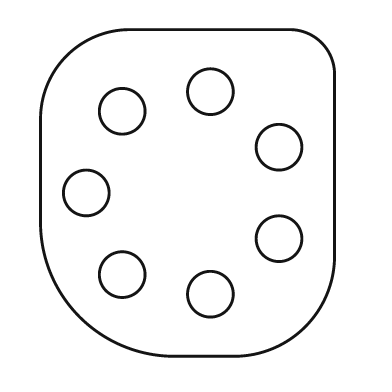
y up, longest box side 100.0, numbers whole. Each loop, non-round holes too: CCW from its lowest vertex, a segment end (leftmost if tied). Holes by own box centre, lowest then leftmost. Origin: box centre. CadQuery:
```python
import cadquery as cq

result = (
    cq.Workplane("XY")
    .moveTo(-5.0, -50.0)
    .lineTo(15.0, -50.0)
    .threePointArc((36.0, -41.0), (45.0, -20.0))
    .lineTo(45.0, 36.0)
    .threePointArc((41.0, 46.0), (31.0, 50.0))
    .lineTo(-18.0, 50.0)
    .threePointArc((-37.0, 42.0), (-45.0, 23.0))
    .lineTo(-45.0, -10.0)
    .threePointArc((-33.0, -38.0), (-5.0, -50.0))
    .close()
    .moveTo(7.0, -31.0)
    .circle(7.0)
    .moveTo(-20.0, -25.0)
    .circle(7.0)
    .moveTo(28.0, -14.0)
    .circle(7.0)
    .moveTo(-31.0, 0.0)
    .circle(7.0)
    .moveTo(28.0, 14.0)
    .circle(7.0)
    .moveTo(-20.0, 25.0)
    .circle(7.0)
    .moveTo(7.0, 31.0)
    .circle(7.0)
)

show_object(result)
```